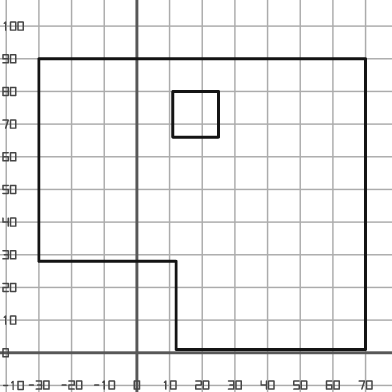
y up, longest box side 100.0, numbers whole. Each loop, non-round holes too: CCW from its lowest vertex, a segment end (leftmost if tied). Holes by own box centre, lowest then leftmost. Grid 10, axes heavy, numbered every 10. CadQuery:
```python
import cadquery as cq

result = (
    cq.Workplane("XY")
    .moveTo(12.0, 1.0)
    .lineTo(70.0, 1.0)
    .lineTo(70.0, 90.0)
    .lineTo(-30.0, 90.0)
    .lineTo(-30.0, 28.0)
    .lineTo(12.0, 28.0)
    .close()
    .moveTo(11.0, 66.0)
    .lineTo(25.0, 66.0)
    .lineTo(25.0, 80.0)
    .lineTo(11.0, 80.0)
    .close()
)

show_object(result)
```